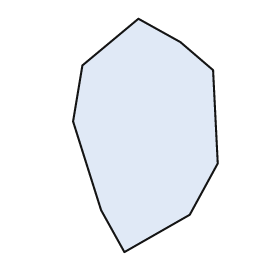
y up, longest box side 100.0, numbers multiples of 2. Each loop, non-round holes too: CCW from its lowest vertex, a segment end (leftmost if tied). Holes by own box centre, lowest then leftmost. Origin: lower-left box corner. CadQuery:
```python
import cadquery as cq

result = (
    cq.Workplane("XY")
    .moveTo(22.0, 0.0)
    .lineTo(50.0, 16.0)
    .lineTo(62.0, 38.0)
    .lineTo(60.0, 78.0)
    .lineTo(46.0, 90.0)
    .lineTo(28.0, 100.0)
    .lineTo(4.0, 80.0)
    .lineTo(0.0, 56.0)
    .lineTo(12.0, 18.0)
    .close()
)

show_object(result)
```